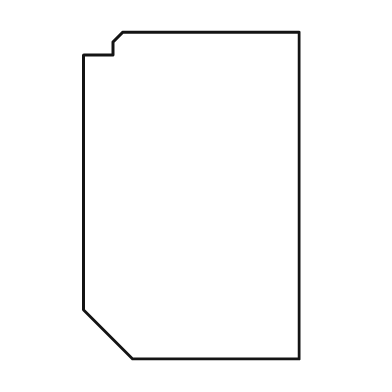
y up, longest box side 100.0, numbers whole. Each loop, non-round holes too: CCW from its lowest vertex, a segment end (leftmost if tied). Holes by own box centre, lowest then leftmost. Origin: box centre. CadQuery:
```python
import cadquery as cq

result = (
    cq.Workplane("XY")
    .moveTo(-18.0, -50.0)
    .lineTo(33.0, -50.0)
    .lineTo(33.0, 50.0)
    .lineTo(-21.0, 50.0)
    .lineTo(-24.0, 47.0)
    .lineTo(-24.0, 43.0)
    .lineTo(-33.0, 43.0)
    .lineTo(-33.0, -35.0)
    .close()
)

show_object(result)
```